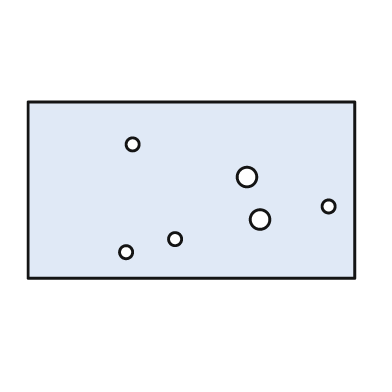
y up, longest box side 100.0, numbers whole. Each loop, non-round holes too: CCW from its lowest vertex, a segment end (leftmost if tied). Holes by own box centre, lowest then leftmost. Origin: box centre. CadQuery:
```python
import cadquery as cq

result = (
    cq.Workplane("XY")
    .moveTo(-50.0, -27.0)
    .lineTo(50.0, -27.0)
    .lineTo(50.0, 27.0)
    .lineTo(-50.0, 27.0)
    .close()
    .moveTo(-20.0, -19.0)
    .circle(2.0)
    .moveTo(-5.0, -15.0)
    .circle(2.0)
    .moveTo(21.0, -9.0)
    .circle(3.0)
    .moveTo(42.0, -5.0)
    .circle(2.0)
    .moveTo(17.0, 4.0)
    .circle(3.0)
    .moveTo(-18.0, 14.0)
    .circle(2.0)
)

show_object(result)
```